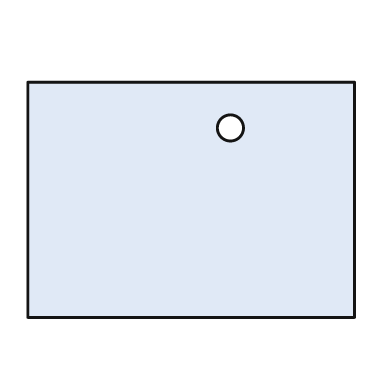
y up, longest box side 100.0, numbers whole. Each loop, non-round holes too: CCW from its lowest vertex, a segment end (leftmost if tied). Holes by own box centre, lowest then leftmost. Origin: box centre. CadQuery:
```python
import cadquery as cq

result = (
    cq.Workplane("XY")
    .moveTo(-50.0, -36.0)
    .lineTo(50.0, -36.0)
    .lineTo(50.0, 36.0)
    .lineTo(-50.0, 36.0)
    .close()
    .moveTo(12.0, 22.0)
    .circle(4.0)
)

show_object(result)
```